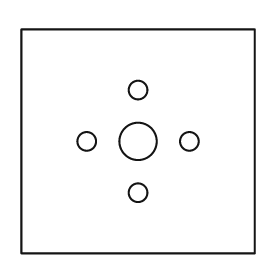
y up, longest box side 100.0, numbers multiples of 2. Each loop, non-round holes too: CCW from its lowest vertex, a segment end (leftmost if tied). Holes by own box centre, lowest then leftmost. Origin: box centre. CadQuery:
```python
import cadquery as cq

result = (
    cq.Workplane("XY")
    .moveTo(-50.0, -48.0)
    .lineTo(50.0, -48.0)
    .lineTo(50.0, 48.0)
    .lineTo(-50.0, 48.0)
    .close()
    .moveTo(0.0, -22.0)
    .circle(4.0)
    .moveTo(-22.0, 0.0)
    .circle(4.0)
    .moveTo(0.0, 0.0)
    .circle(8.0)
    .moveTo(22.0, 0.0)
    .circle(4.0)
    .moveTo(0.0, 22.0)
    .circle(4.0)
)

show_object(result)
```